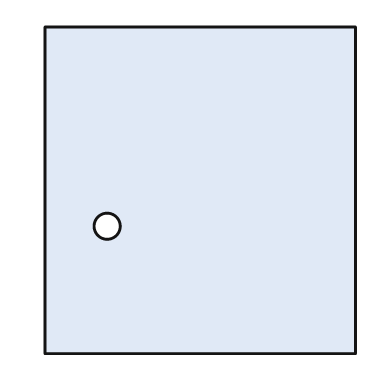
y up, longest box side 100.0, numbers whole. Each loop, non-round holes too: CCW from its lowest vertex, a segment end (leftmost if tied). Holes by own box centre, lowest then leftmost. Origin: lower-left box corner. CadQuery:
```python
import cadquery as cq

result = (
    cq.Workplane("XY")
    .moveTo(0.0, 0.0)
    .lineTo(95.0, 0.0)
    .lineTo(95.0, 100.0)
    .lineTo(0.0, 100.0)
    .close()
    .moveTo(19.0, 39.0)
    .circle(4.0)
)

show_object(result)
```